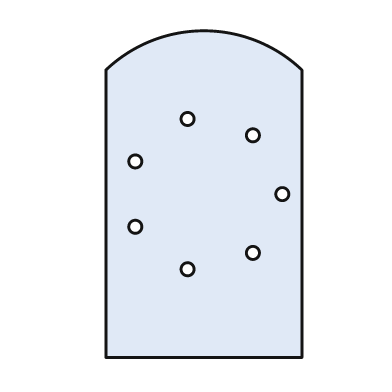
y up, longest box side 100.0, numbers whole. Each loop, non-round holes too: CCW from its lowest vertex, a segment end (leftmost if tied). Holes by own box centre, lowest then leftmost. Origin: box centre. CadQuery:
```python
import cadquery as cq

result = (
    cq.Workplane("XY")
    .moveTo(-30.0, -50.0)
    .lineTo(30.0, -50.0)
    .lineTo(30.0, 38.0)
    .threePointArc((0.0, 50.0), (-30.0, 38.0))
    .close()
    .moveTo(-5.0, -23.0)
    .circle(2.0)
    .moveTo(15.0, -18.0)
    .circle(2.0)
    .moveTo(-21.0, -10.0)
    .circle(2.0)
    .moveTo(24.0, 0.0)
    .circle(2.0)
    .moveTo(-21.0, 10.0)
    .circle(2.0)
    .moveTo(15.0, 18.0)
    .circle(2.0)
    .moveTo(-5.0, 23.0)
    .circle(2.0)
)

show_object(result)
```